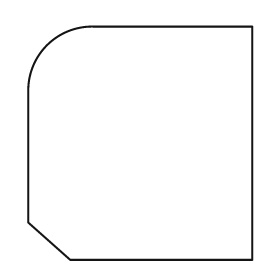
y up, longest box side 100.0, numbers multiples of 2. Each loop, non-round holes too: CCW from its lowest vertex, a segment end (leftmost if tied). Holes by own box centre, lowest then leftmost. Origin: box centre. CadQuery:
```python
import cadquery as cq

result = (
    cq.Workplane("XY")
    .moveTo(-30.0, -50.0)
    .lineTo(48.0, -50.0)
    .lineTo(48.0, 50.0)
    .lineTo(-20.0, 50.0)
    .threePointArc((-40.0, 42.0), (-48.0, 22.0))
    .lineTo(-48.0, -34.0)
    .close()
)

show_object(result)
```